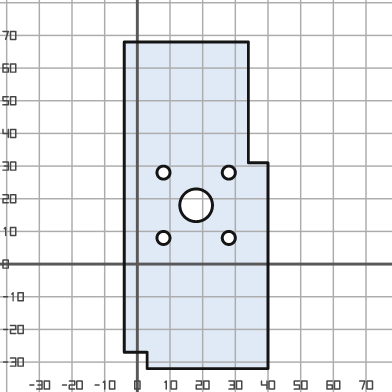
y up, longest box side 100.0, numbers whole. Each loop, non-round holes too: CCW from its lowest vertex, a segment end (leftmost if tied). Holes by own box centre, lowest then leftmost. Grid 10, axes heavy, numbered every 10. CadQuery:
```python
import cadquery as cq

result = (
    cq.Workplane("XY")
    .moveTo(3.0, -32.0)
    .lineTo(40.0, -32.0)
    .lineTo(40.0, 31.0)
    .lineTo(34.0, 31.0)
    .lineTo(34.0, 68.0)
    .lineTo(-4.0, 68.0)
    .lineTo(-4.0, -27.0)
    .lineTo(3.0, -27.0)
    .close()
    .moveTo(8.0, 8.0)
    .circle(2.0)
    .moveTo(28.0, 8.0)
    .circle(2.0)
    .moveTo(18.0, 18.0)
    .circle(5.0)
    .moveTo(8.0, 28.0)
    .circle(2.0)
    .moveTo(28.0, 28.0)
    .circle(2.0)
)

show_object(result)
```